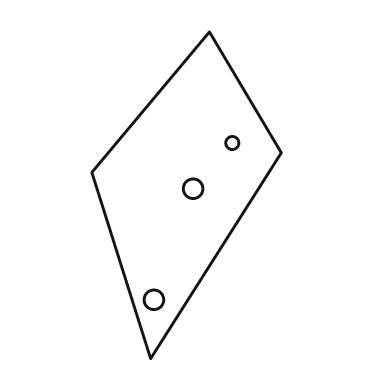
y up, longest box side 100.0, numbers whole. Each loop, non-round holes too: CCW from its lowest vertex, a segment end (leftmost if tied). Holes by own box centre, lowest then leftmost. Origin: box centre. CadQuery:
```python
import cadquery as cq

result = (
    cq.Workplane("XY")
    .moveTo(-11.0, -50.0)
    .lineTo(29.0, 13.0)
    .lineTo(7.0, 50.0)
    .lineTo(-29.0, 7.0)
    .close()
    .moveTo(-10.0, -32.0)
    .circle(3.0)
    .moveTo(2.0, 2.0)
    .circle(3.0)
    .moveTo(14.0, 16.0)
    .circle(2.0)
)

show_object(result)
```